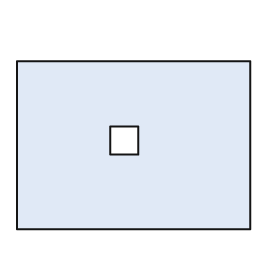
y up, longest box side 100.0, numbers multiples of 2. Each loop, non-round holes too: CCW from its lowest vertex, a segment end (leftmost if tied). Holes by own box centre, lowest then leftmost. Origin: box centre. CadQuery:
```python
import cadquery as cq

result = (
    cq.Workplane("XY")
    .moveTo(-50.0, -36.0)
    .lineTo(50.0, -36.0)
    .lineTo(50.0, 36.0)
    .lineTo(-50.0, 36.0)
    .close()
    .moveTo(-10.0, -4.0)
    .lineTo(2.0, -4.0)
    .lineTo(2.0, 8.0)
    .lineTo(-10.0, 8.0)
    .close()
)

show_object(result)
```